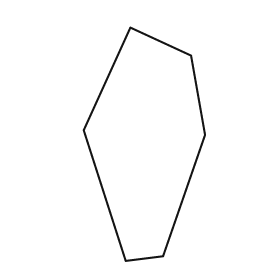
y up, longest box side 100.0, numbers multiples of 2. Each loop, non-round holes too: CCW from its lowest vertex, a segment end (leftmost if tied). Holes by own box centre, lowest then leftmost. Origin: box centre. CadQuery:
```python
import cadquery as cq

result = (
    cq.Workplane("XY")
    .moveTo(-8.0, -50.0)
    .lineTo(8.0, -48.0)
    .lineTo(26.0, 4.0)
    .lineTo(20.0, 38.0)
    .lineTo(-6.0, 50.0)
    .lineTo(-26.0, 6.0)
    .close()
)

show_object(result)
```